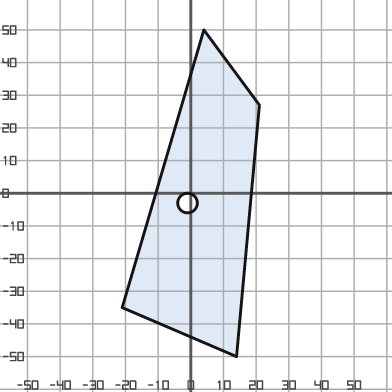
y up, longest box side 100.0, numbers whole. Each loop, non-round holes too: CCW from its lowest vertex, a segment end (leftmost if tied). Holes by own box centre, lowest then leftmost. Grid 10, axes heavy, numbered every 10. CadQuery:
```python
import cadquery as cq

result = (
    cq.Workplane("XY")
    .moveTo(14.0, -50.0)
    .lineTo(21.0, 27.0)
    .lineTo(4.0, 50.0)
    .lineTo(-21.0, -35.0)
    .close()
    .moveTo(-1.0, -3.0)
    .circle(3.0)
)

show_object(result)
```